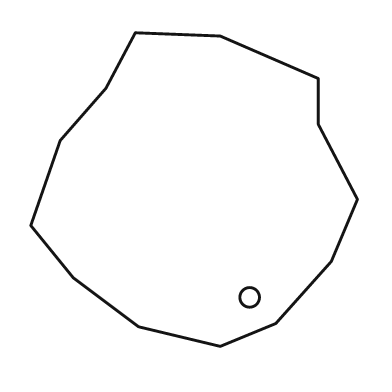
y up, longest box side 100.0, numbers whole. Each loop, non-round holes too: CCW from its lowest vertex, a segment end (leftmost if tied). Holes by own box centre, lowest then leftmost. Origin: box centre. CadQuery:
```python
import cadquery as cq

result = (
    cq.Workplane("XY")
    .moveTo(8.0, -48.0)
    .lineTo(25.0, -41.0)
    .lineTo(42.0, -22.0)
    .lineTo(50.0, -3.0)
    .lineTo(38.0, 20.0)
    .lineTo(38.0, 34.0)
    .lineTo(8.0, 47.0)
    .lineTo(-18.0, 48.0)
    .lineTo(-27.0, 31.0)
    .lineTo(-41.0, 15.0)
    .lineTo(-50.0, -11.0)
    .lineTo(-37.0, -27.0)
    .lineTo(-17.0, -42.0)
    .close()
    .moveTo(17.0, -33.0)
    .circle(3.0)
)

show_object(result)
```